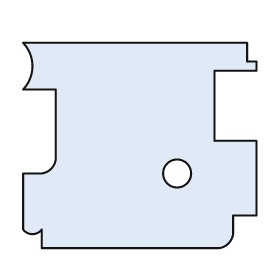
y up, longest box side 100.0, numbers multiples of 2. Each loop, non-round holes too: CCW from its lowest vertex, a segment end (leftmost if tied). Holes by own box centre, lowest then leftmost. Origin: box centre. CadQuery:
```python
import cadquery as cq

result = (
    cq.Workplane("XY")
    .moveTo(-42.0, -44.0)
    .lineTo(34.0, -44.0)
    .threePointArc((38.0, -42.0), (40.0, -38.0))
    .lineTo(40.0, -30.0)
    .lineTo(50.0, -30.0)
    .lineTo(50.0, 2.0)
    .lineTo(32.0, 2.0)
    .lineTo(32.0, 32.0)
    .lineTo(50.0, 32.0)
    .lineTo(50.0, 36.0)
    .lineTo(46.0, 36.0)
    .lineTo(46.0, 44.0)
    .lineTo(-50.0, 44.0)
    .threePointArc((-46.0, 34.0), (-50.0, 24.0))
    .lineTo(-36.0, 24.0)
    .lineTo(-36.0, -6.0)
    .threePointArc((-38.0, -10.0), (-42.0, -12.0))
    .lineTo(-50.0, -12.0)
    .lineTo(-50.0, -36.0)
    .threePointArc((-46.0, -38.0), (-42.0, -36.0))
    .close()
    .moveTo(16.0, -12.0)
    .circle(6.0)
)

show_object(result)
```